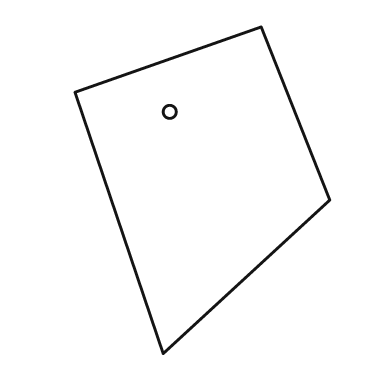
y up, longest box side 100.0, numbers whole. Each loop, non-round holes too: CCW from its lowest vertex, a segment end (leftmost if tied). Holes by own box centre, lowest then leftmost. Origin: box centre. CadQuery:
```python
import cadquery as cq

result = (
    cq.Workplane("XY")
    .moveTo(-12.0, -50.0)
    .lineTo(39.0, -3.0)
    .lineTo(18.0, 50.0)
    .lineTo(-39.0, 30.0)
    .close()
    .moveTo(-10.0, 24.0)
    .circle(2.0)
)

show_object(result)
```